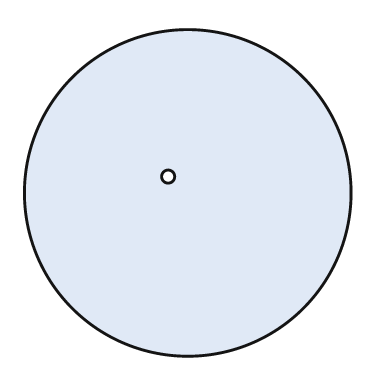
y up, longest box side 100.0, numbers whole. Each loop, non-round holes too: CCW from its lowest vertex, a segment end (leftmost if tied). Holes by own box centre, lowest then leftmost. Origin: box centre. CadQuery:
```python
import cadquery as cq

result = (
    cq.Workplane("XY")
    .moveTo(0.0, 0.0)
    .circle(50.0)
    .moveTo(-6.0, 5.0)
    .circle(2.0)
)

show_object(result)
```